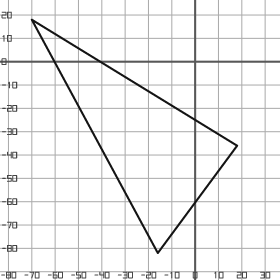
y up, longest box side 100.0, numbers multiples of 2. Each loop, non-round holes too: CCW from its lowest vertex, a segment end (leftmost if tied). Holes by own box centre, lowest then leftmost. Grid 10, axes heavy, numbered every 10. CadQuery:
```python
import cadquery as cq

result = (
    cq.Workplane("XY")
    .moveTo(-16.0, -82.0)
    .lineTo(18.0, -36.0)
    .lineTo(-70.0, 18.0)
    .close()
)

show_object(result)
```